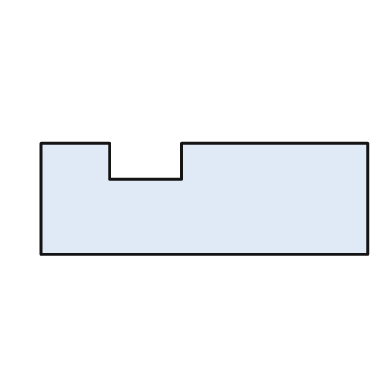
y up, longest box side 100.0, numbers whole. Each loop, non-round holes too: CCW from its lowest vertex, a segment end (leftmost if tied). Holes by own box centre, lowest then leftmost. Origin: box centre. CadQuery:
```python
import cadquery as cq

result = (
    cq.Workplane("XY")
    .moveTo(-50.0, -17.0)
    .lineTo(50.0, -17.0)
    .lineTo(50.0, 17.0)
    .lineTo(-7.0, 17.0)
    .lineTo(-7.0, 6.0)
    .lineTo(-29.0, 6.0)
    .lineTo(-29.0, 17.0)
    .lineTo(-50.0, 17.0)
    .close()
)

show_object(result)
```